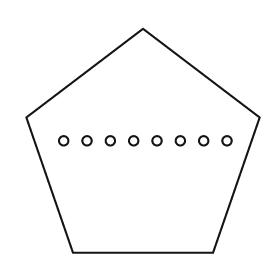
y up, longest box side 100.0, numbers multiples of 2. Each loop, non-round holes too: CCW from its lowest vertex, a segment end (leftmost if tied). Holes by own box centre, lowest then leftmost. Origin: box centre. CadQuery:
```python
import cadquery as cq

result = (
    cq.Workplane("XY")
    .moveTo(-30.0, -48.0)
    .lineTo(30.0, -48.0)
    .lineTo(50.0, 10.0)
    .lineTo(0.0, 48.0)
    .lineTo(-50.0, 10.0)
    .close()
    .moveTo(-34.0, 0.0)
    .circle(2.0)
    .moveTo(-24.0, 0.0)
    .circle(2.0)
    .moveTo(-14.0, 0.0)
    .circle(2.0)
    .moveTo(-4.0, 0.0)
    .circle(2.0)
    .moveTo(6.0, 0.0)
    .circle(2.0)
    .moveTo(16.0, 0.0)
    .circle(2.0)
    .moveTo(26.0, 0.0)
    .circle(2.0)
    .moveTo(36.0, 0.0)
    .circle(2.0)
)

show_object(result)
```